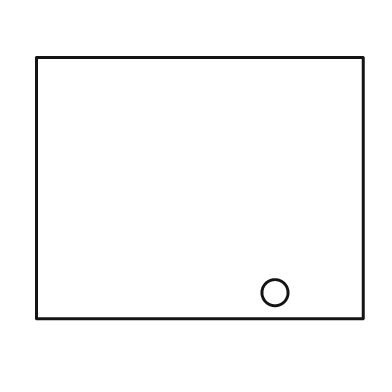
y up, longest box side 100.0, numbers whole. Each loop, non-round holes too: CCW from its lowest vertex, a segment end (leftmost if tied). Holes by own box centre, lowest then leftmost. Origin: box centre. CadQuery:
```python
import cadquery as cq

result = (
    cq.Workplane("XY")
    .moveTo(-50.0, -40.0)
    .lineTo(50.0, -40.0)
    .lineTo(50.0, 40.0)
    .lineTo(-50.0, 40.0)
    .close()
    .moveTo(23.0, -32.0)
    .circle(4.0)
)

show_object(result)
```